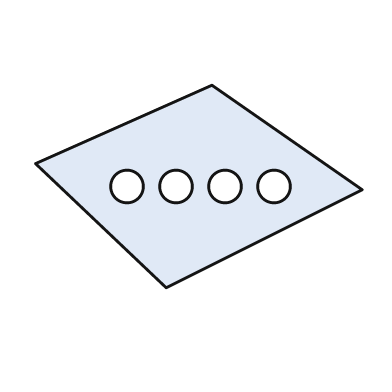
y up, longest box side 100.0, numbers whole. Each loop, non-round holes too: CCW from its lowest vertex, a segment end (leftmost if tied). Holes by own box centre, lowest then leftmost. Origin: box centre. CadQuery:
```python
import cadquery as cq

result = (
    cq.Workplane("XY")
    .moveTo(-10.0, -31.0)
    .lineTo(50.0, -1.0)
    .lineTo(4.0, 31.0)
    .lineTo(-50.0, 7.0)
    .close()
    .moveTo(-22.0, 0.0)
    .circle(5.0)
    .moveTo(-7.0, 0.0)
    .circle(5.0)
    .moveTo(8.0, 0.0)
    .circle(5.0)
    .moveTo(23.0, 0.0)
    .circle(5.0)
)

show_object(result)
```